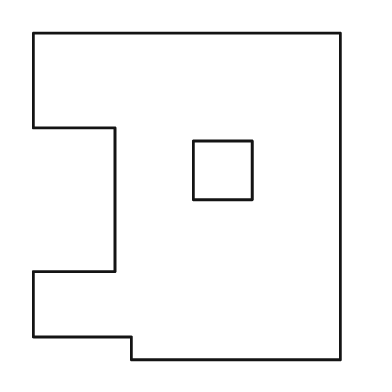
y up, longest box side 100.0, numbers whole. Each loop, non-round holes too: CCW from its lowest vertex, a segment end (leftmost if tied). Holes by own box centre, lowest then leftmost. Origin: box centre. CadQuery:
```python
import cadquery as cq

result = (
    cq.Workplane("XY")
    .moveTo(-17.0, -50.0)
    .lineTo(47.0, -50.0)
    .lineTo(47.0, 50.0)
    .lineTo(-47.0, 50.0)
    .lineTo(-47.0, 21.0)
    .lineTo(-22.0, 21.0)
    .lineTo(-22.0, -23.0)
    .lineTo(-47.0, -23.0)
    .lineTo(-47.0, -43.0)
    .lineTo(-17.0, -43.0)
    .close()
    .moveTo(2.0, -1.0)
    .lineTo(20.0, -1.0)
    .lineTo(20.0, 17.0)
    .lineTo(2.0, 17.0)
    .close()
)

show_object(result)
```